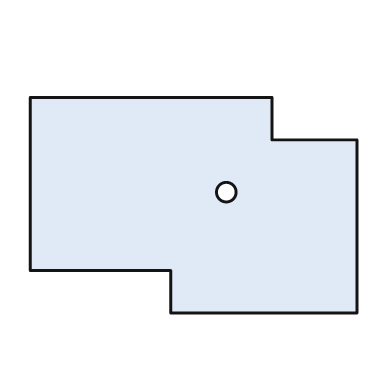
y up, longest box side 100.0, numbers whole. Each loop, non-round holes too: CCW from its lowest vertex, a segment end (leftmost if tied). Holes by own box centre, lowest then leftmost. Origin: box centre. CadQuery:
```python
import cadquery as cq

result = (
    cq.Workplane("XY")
    .moveTo(-7.0, -33.0)
    .lineTo(50.0, -33.0)
    .lineTo(50.0, 20.0)
    .lineTo(24.0, 20.0)
    .lineTo(24.0, 33.0)
    .lineTo(-50.0, 33.0)
    .lineTo(-50.0, -20.0)
    .lineTo(-7.0, -20.0)
    .close()
    .moveTo(10.0, 4.0)
    .circle(3.0)
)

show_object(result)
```